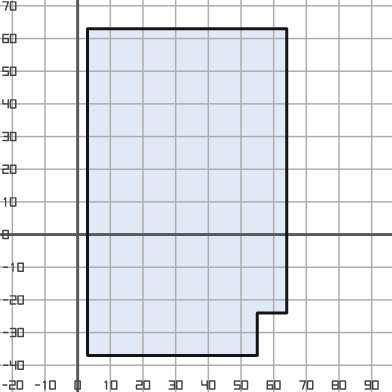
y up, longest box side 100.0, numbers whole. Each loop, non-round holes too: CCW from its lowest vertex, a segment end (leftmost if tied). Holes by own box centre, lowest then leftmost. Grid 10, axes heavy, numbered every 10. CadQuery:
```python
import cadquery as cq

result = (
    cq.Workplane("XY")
    .moveTo(3.0, -37.0)
    .lineTo(55.0, -37.0)
    .lineTo(55.0, -24.0)
    .lineTo(64.0, -24.0)
    .lineTo(64.0, 63.0)
    .lineTo(3.0, 63.0)
    .close()
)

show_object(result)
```